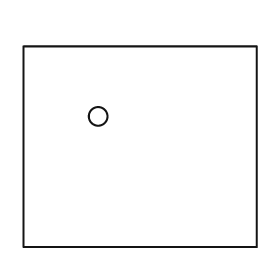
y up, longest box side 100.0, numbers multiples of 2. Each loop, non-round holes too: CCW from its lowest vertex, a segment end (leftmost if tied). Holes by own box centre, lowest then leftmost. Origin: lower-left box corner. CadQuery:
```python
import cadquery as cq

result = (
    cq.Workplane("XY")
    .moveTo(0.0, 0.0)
    .lineTo(100.0, 0.0)
    .lineTo(100.0, 86.0)
    .lineTo(0.0, 86.0)
    .close()
    .moveTo(32.0, 56.0)
    .circle(4.0)
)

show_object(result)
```